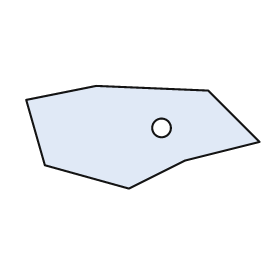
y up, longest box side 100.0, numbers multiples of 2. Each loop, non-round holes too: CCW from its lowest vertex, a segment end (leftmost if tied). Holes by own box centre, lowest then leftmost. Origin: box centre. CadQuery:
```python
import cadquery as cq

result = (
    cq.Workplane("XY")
    .moveTo(-6.0, -22.0)
    .lineTo(18.0, -10.0)
    .lineTo(50.0, -2.0)
    .lineTo(28.0, 20.0)
    .lineTo(-20.0, 22.0)
    .lineTo(-50.0, 16.0)
    .lineTo(-42.0, -12.0)
    .close()
    .moveTo(8.0, 4.0)
    .circle(4.0)
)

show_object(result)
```